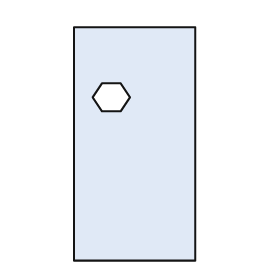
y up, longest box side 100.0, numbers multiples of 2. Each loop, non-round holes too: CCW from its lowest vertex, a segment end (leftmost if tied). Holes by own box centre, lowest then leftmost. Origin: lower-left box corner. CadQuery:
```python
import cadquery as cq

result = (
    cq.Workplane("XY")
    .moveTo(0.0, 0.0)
    .lineTo(52.0, 0.0)
    .lineTo(52.0, 100.0)
    .lineTo(0.0, 100.0)
    .close()
    .moveTo(12.0, 64.0)
    .lineTo(20.0, 64.0)
    .lineTo(24.0, 70.0)
    .lineTo(20.0, 76.0)
    .lineTo(12.0, 76.0)
    .lineTo(8.0, 70.0)
    .close()
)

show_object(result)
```